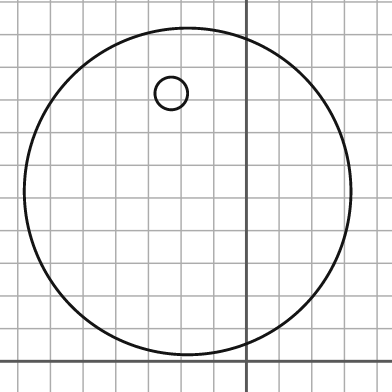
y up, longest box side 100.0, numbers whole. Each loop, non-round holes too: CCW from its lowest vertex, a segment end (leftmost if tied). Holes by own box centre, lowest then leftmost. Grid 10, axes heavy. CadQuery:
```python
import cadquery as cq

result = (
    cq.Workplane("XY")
    .moveTo(-18.0, 52.0)
    .circle(50.0)
    .moveTo(-23.0, 82.0)
    .circle(5.0)
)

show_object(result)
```